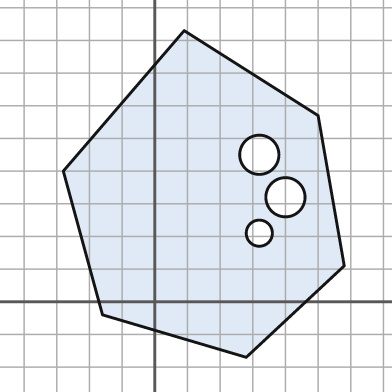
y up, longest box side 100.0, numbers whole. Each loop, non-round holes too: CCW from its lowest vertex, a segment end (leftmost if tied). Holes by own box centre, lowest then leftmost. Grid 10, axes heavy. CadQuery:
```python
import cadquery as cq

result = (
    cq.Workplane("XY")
    .moveTo(28.0, -17.0)
    .lineTo(58.0, 11.0)
    .lineTo(50.0, 57.0)
    .lineTo(9.0, 83.0)
    .lineTo(-28.0, 40.0)
    .lineTo(-16.0, -4.0)
    .close()
    .moveTo(32.0, 21.0)
    .circle(4.0)
    .moveTo(40.0, 32.0)
    .circle(6.0)
    .moveTo(32.0, 45.0)
    .circle(6.0)
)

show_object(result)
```